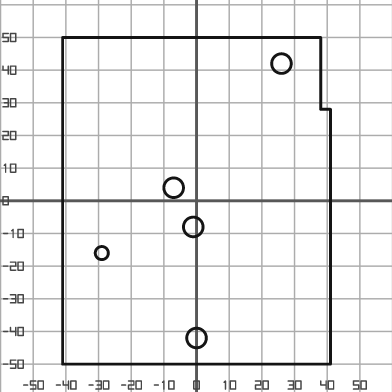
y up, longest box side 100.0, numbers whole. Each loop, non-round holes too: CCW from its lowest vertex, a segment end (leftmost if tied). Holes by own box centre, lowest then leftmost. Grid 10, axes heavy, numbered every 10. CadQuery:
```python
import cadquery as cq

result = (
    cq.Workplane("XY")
    .moveTo(-41.0, -50.0)
    .lineTo(41.0, -50.0)
    .lineTo(41.0, 28.0)
    .lineTo(38.0, 28.0)
    .lineTo(38.0, 50.0)
    .lineTo(-41.0, 50.0)
    .close()
    .moveTo(0.0, -42.0)
    .circle(3.0)
    .moveTo(-29.0, -16.0)
    .circle(2.0)
    .moveTo(-1.0, -8.0)
    .circle(3.0)
    .moveTo(-7.0, 4.0)
    .circle(3.0)
    .moveTo(26.0, 42.0)
    .circle(3.0)
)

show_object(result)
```